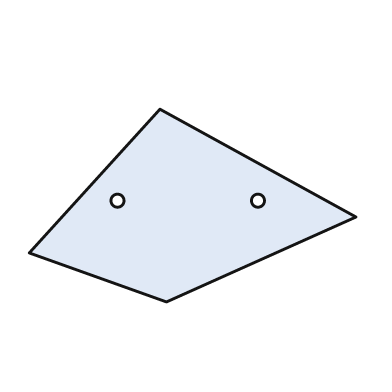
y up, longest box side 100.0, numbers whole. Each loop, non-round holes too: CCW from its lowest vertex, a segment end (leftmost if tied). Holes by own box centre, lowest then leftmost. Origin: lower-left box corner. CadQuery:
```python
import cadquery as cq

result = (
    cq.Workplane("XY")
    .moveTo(42.0, 0.0)
    .lineTo(100.0, 26.0)
    .lineTo(40.0, 59.0)
    .lineTo(0.0, 15.0)
    .close()
    .moveTo(27.0, 31.0)
    .circle(2.0)
    .moveTo(70.0, 31.0)
    .circle(2.0)
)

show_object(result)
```